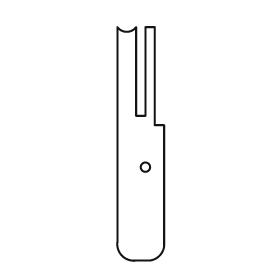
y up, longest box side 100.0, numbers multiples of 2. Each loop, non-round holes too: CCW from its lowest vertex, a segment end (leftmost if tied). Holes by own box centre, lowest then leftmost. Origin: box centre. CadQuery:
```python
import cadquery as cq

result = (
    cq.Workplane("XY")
    .moveTo(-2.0, -50.0)
    .lineTo(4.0, -50.0)
    .threePointArc((8.0, -48.0), (10.0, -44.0))
    .lineTo(10.0, 8.0)
    .lineTo(6.0, 8.0)
    .lineTo(6.0, 50.0)
    .lineTo(2.0, 50.0)
    .lineTo(2.0, 12.0)
    .lineTo(-2.0, 12.0)
    .lineTo(-2.0, 50.0)
    .threePointArc((-6.0, 48.0), (-10.0, 50.0))
    .lineTo(-10.0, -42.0)
    .threePointArc((-8.0, -48.0), (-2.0, -50.0))
    .close()
    .moveTo(2.0, -10.0)
    .circle(2.0)
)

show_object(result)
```